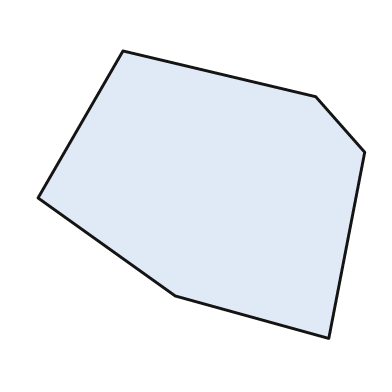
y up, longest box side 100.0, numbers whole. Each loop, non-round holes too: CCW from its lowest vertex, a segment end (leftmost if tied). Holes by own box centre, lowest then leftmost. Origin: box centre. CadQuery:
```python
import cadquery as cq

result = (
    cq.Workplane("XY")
    .moveTo(39.0, -44.0)
    .lineTo(50.0, 13.0)
    .lineTo(35.0, 30.0)
    .lineTo(-24.0, 44.0)
    .lineTo(-50.0, -1.0)
    .lineTo(-8.0, -31.0)
    .close()
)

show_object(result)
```